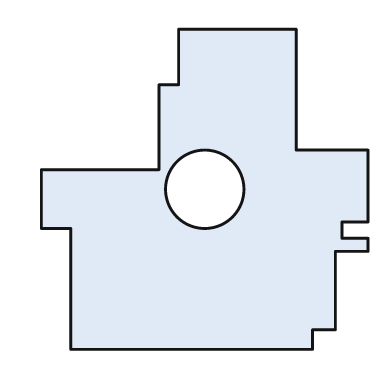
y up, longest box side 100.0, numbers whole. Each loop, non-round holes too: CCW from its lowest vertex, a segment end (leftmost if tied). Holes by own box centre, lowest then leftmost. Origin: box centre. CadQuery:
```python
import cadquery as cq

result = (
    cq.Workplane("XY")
    .moveTo(-41.0, -49.0)
    .lineTo(33.0, -49.0)
    .lineTo(33.0, -43.0)
    .lineTo(40.0, -43.0)
    .lineTo(40.0, -19.0)
    .lineTo(50.0, -19.0)
    .lineTo(50.0, -15.0)
    .lineTo(42.0, -15.0)
    .lineTo(42.0, -10.0)
    .lineTo(50.0, -10.0)
    .lineTo(50.0, 12.0)
    .lineTo(28.0, 12.0)
    .lineTo(28.0, 49.0)
    .lineTo(-8.0, 49.0)
    .lineTo(-8.0, 32.0)
    .lineTo(-14.0, 32.0)
    .lineTo(-14.0, 6.0)
    .lineTo(-50.0, 6.0)
    .lineTo(-50.0, -12.0)
    .lineTo(-41.0, -12.0)
    .close()
    .moveTo(0.0, 0.0)
    .circle(12.0)
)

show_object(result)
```